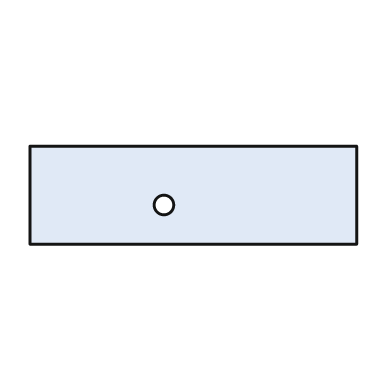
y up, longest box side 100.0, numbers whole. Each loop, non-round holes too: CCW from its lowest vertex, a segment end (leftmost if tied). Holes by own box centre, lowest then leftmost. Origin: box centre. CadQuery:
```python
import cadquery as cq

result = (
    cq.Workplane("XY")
    .moveTo(-50.0, -15.0)
    .lineTo(50.0, -15.0)
    .lineTo(50.0, 15.0)
    .lineTo(-50.0, 15.0)
    .close()
    .moveTo(-9.0, -3.0)
    .circle(3.0)
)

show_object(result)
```